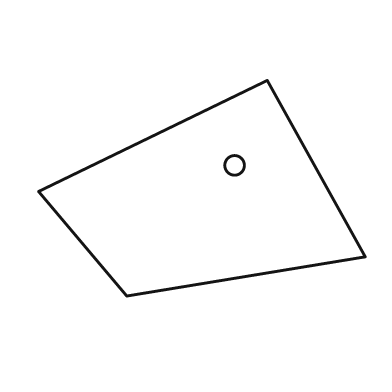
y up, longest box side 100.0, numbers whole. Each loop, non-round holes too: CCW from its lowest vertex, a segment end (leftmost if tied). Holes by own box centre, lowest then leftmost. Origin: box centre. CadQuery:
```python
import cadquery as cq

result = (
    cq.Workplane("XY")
    .moveTo(-23.0, -33.0)
    .lineTo(50.0, -21.0)
    .lineTo(20.0, 33.0)
    .lineTo(-50.0, -1.0)
    .close()
    .moveTo(10.0, 7.0)
    .circle(3.0)
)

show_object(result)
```